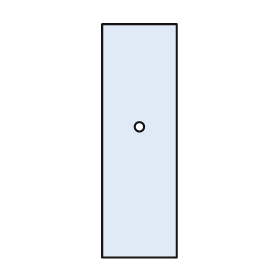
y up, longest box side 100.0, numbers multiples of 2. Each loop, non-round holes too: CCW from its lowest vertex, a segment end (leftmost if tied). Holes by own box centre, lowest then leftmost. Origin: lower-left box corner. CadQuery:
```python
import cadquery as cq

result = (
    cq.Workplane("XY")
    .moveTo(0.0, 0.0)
    .lineTo(32.0, 0.0)
    .lineTo(32.0, 100.0)
    .lineTo(0.0, 100.0)
    .close()
    .moveTo(16.0, 56.0)
    .circle(2.0)
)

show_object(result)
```